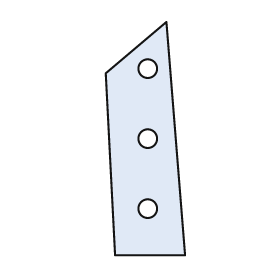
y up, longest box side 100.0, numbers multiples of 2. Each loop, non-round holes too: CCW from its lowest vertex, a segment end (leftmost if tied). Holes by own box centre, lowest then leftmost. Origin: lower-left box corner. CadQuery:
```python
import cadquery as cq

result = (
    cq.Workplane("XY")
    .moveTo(4.0, 0.0)
    .lineTo(34.0, 0.0)
    .lineTo(26.0, 100.0)
    .lineTo(0.0, 78.0)
    .close()
    .moveTo(18.0, 20.0)
    .circle(4.0)
    .moveTo(18.0, 50.0)
    .circle(4.0)
    .moveTo(18.0, 80.0)
    .circle(4.0)
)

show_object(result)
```